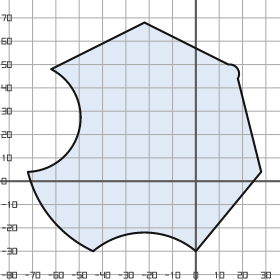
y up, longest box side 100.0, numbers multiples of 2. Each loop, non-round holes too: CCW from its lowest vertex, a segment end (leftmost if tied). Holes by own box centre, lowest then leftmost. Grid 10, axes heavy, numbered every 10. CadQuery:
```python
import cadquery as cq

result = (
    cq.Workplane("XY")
    .moveTo(-44.0, -30.0)
    .threePointArc((-22.0, -22.0), (0.0, -30.0))
    .lineTo(28.0, 4.0)
    .lineTo(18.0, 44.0)
    .threePointArc((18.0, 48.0), (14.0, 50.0))
    .lineTo(-22.0, 68.0)
    .lineTo(-62.0, 48.0)
    .threePointArc((-50.0, 22.0), (-72.0, 4.0))
    .threePointArc((-62.0, -16.0), (-44.0, -30.0))
    .close()
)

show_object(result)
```